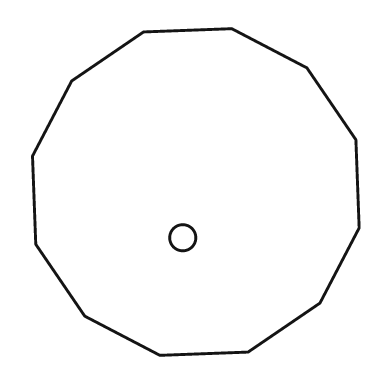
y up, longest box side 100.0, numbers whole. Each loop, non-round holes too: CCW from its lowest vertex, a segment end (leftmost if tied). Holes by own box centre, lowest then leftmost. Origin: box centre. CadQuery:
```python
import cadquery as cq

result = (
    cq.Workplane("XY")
    .moveTo(-11.0, -50.0)
    .lineTo(16.0, -49.0)
    .lineTo(38.0, -34.0)
    .lineTo(50.0, -11.0)
    .lineTo(49.0, 16.0)
    .lineTo(34.0, 38.0)
    .lineTo(11.0, 50.0)
    .lineTo(-16.0, 49.0)
    .lineTo(-38.0, 34.0)
    .lineTo(-50.0, 11.0)
    .lineTo(-49.0, -16.0)
    .lineTo(-34.0, -38.0)
    .close()
    .moveTo(-4.0, -14.0)
    .circle(4.0)
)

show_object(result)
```